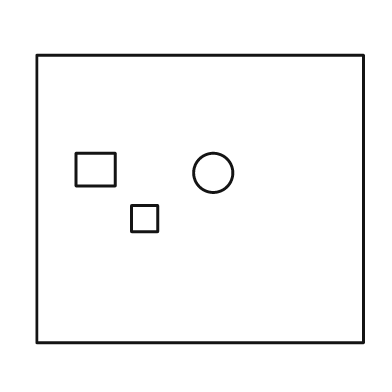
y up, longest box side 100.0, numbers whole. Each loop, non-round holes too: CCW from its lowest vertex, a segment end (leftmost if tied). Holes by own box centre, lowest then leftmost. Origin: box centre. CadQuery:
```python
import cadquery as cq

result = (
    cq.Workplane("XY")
    .moveTo(-50.0, -44.0)
    .lineTo(50.0, -44.0)
    .lineTo(50.0, 44.0)
    .lineTo(-50.0, 44.0)
    .close()
    .moveTo(-21.0, -10.0)
    .lineTo(-13.0, -10.0)
    .lineTo(-13.0, -2.0)
    .lineTo(-21.0, -2.0)
    .close()
    .moveTo(4.0, 8.0)
    .circle(6.0)
    .moveTo(-38.0, 4.0)
    .lineTo(-26.0, 4.0)
    .lineTo(-26.0, 14.0)
    .lineTo(-38.0, 14.0)
    .close()
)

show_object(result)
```